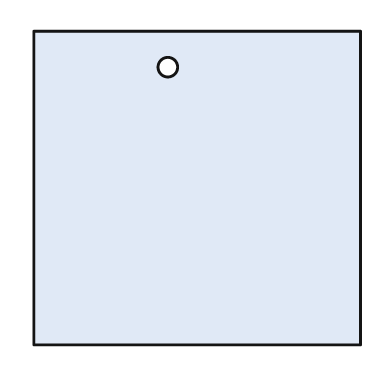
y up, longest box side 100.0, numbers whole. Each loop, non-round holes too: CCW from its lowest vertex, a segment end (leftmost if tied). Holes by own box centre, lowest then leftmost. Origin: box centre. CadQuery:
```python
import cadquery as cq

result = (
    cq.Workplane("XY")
    .moveTo(-50.0, -48.0)
    .lineTo(50.0, -48.0)
    .lineTo(50.0, 48.0)
    .lineTo(-50.0, 48.0)
    .close()
    .moveTo(-9.0, 37.0)
    .circle(3.0)
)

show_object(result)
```